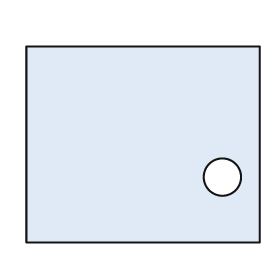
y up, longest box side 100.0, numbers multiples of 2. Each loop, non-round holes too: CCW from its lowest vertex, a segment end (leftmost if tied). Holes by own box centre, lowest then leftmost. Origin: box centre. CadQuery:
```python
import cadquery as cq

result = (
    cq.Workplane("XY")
    .moveTo(-50.0, -42.0)
    .lineTo(50.0, -42.0)
    .lineTo(50.0, 42.0)
    .lineTo(-50.0, 42.0)
    .close()
    .moveTo(34.0, -14.0)
    .circle(8.0)
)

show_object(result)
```